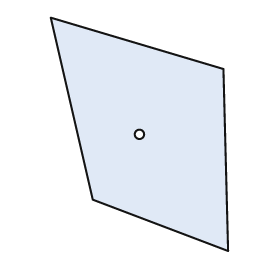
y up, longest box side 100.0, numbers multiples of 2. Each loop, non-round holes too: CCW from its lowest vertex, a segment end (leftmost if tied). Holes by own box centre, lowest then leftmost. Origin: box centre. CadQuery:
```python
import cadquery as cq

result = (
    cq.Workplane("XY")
    .moveTo(38.0, -50.0)
    .lineTo(36.0, 28.0)
    .lineTo(-38.0, 50.0)
    .lineTo(-20.0, -28.0)
    .close()
    .moveTo(0.0, 0.0)
    .circle(2.0)
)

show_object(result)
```